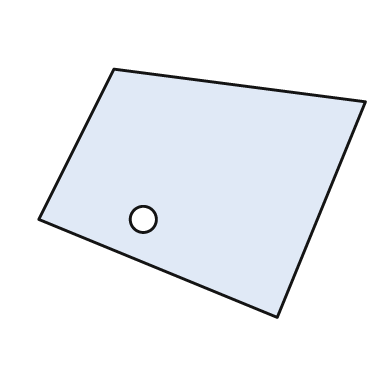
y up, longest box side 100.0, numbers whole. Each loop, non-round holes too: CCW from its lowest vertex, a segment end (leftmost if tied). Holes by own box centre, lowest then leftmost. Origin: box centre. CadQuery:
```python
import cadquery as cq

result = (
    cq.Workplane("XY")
    .moveTo(23.0, -38.0)
    .lineTo(50.0, 28.0)
    .lineTo(-27.0, 38.0)
    .lineTo(-50.0, -8.0)
    .close()
    .moveTo(-18.0, -8.0)
    .circle(4.0)
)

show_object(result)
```